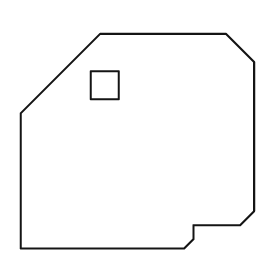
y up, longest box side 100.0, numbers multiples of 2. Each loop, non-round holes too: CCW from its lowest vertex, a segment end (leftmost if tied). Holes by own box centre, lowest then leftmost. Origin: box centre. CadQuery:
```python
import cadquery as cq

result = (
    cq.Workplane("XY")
    .moveTo(-50.0, -46.0)
    .lineTo(20.0, -46.0)
    .lineTo(24.0, -42.0)
    .lineTo(24.0, -36.0)
    .lineTo(44.0, -36.0)
    .lineTo(50.0, -30.0)
    .lineTo(50.0, 34.0)
    .lineTo(38.0, 46.0)
    .lineTo(-16.0, 46.0)
    .lineTo(-50.0, 12.0)
    .close()
    .moveTo(-20.0, 18.0)
    .lineTo(-8.0, 18.0)
    .lineTo(-8.0, 30.0)
    .lineTo(-20.0, 30.0)
    .close()
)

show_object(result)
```